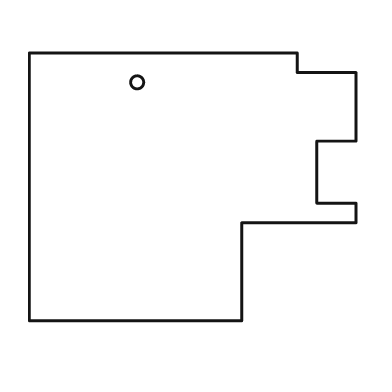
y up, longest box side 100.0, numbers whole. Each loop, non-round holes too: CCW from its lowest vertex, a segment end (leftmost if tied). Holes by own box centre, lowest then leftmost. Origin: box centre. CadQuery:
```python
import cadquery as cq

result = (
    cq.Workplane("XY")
    .moveTo(-50.0, -41.0)
    .lineTo(15.0, -41.0)
    .lineTo(15.0, -11.0)
    .lineTo(50.0, -11.0)
    .lineTo(50.0, -5.0)
    .lineTo(38.0, -5.0)
    .lineTo(38.0, 14.0)
    .lineTo(50.0, 14.0)
    .lineTo(50.0, 35.0)
    .lineTo(32.0, 35.0)
    .lineTo(32.0, 41.0)
    .lineTo(-50.0, 41.0)
    .close()
    .moveTo(-17.0, 32.0)
    .circle(2.0)
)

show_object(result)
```